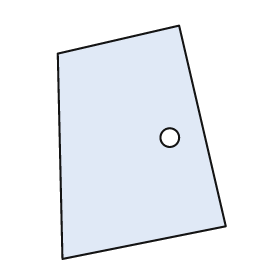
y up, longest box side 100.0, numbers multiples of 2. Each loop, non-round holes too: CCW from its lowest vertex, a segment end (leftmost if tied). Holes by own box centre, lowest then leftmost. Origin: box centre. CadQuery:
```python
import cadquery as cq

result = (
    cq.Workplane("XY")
    .moveTo(-34.0, -50.0)
    .lineTo(36.0, -36.0)
    .lineTo(16.0, 50.0)
    .lineTo(-36.0, 38.0)
    .close()
    .moveTo(12.0, 2.0)
    .circle(4.0)
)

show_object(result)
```